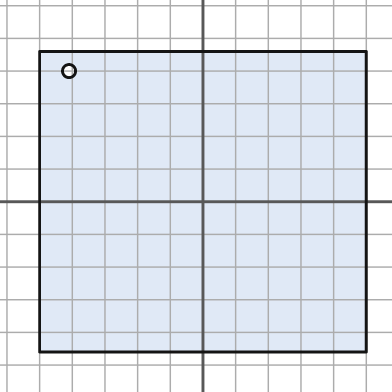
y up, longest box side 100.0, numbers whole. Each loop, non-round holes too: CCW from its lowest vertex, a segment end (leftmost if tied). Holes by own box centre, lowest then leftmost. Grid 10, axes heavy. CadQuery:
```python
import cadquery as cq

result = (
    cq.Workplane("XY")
    .moveTo(-50.0, -46.0)
    .lineTo(50.0, -46.0)
    .lineTo(50.0, 46.0)
    .lineTo(-50.0, 46.0)
    .close()
    .moveTo(-41.0, 40.0)
    .circle(2.0)
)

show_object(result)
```